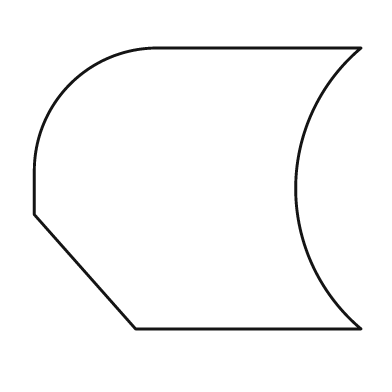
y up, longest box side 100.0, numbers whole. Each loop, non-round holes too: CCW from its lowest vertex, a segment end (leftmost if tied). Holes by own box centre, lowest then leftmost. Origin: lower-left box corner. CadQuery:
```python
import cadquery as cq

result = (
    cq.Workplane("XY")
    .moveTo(31.0, 0.0)
    .lineTo(100.0, 0.0)
    .threePointArc((80.0, 43.0), (100.0, 86.0))
    .lineTo(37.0, 86.0)
    .threePointArc((11.0, 75.0), (0.0, 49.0))
    .lineTo(0.0, 35.0)
    .close()
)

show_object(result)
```